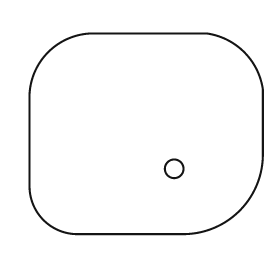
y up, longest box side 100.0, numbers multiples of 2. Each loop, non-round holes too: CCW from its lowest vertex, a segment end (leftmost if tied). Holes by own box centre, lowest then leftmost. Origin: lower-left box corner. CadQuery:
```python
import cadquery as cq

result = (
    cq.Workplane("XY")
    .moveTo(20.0, 0.0)
    .lineTo(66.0, 0.0)
    .threePointArc((90.0, 10.0), (100.0, 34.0))
    .lineTo(100.0, 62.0)
    .threePointArc((92.0, 78.0), (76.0, 86.0))
    .lineTo(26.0, 86.0)
    .threePointArc((8.0, 78.0), (0.0, 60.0))
    .lineTo(0.0, 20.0)
    .threePointArc((6.0, 6.0), (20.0, 0.0))
    .close()
    .moveTo(62.0, 28.0)
    .circle(4.0)
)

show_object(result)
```